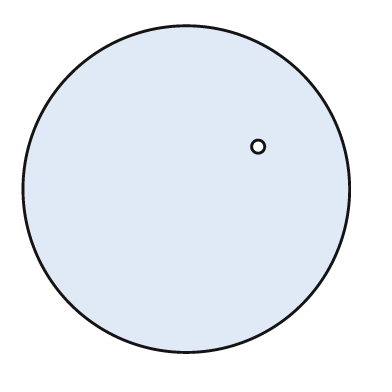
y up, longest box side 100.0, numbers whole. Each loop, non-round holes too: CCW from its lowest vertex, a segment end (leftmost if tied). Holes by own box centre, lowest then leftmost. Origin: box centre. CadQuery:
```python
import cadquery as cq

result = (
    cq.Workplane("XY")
    .moveTo(0.0, 0.0)
    .circle(50.0)
    .moveTo(22.0, 13.0)
    .circle(2.0)
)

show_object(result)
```